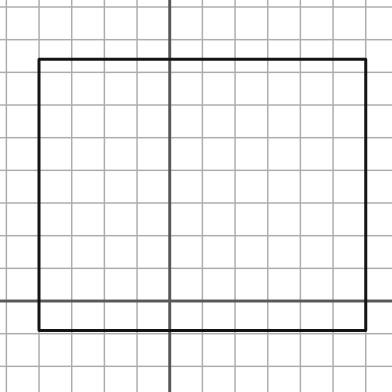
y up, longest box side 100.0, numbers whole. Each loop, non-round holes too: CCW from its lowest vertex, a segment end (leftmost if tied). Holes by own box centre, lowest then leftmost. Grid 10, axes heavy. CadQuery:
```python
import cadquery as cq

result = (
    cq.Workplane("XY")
    .moveTo(-40.0, -9.0)
    .lineTo(60.0, -9.0)
    .lineTo(60.0, 74.0)
    .lineTo(-40.0, 74.0)
    .close()
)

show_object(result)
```